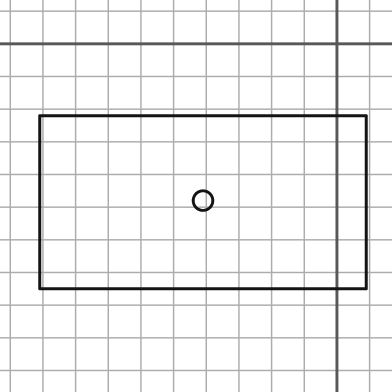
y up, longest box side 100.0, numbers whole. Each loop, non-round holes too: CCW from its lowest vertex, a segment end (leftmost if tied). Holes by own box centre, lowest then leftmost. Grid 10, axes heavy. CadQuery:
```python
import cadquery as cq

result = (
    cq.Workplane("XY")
    .moveTo(-91.0, -75.0)
    .lineTo(9.0, -75.0)
    .lineTo(9.0, -22.0)
    .lineTo(-91.0, -22.0)
    .close()
    .moveTo(-41.0, -48.0)
    .circle(3.0)
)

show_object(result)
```